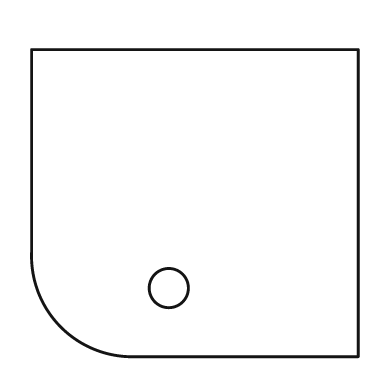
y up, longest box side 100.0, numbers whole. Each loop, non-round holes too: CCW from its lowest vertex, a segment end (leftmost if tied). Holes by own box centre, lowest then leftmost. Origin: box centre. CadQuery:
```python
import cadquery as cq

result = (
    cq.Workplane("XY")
    .moveTo(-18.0, -47.0)
    .lineTo(50.0, -47.0)
    .lineTo(50.0, 47.0)
    .lineTo(-50.0, 47.0)
    .lineTo(-50.0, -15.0)
    .threePointArc((-41.0, -38.0), (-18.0, -47.0))
    .close()
    .moveTo(-8.0, -26.0)
    .circle(6.0)
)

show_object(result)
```